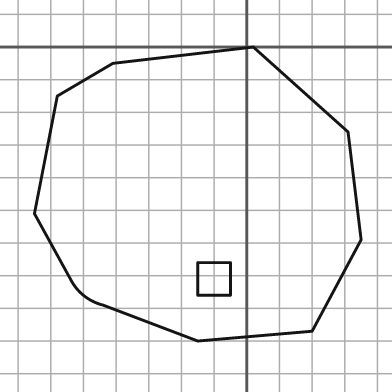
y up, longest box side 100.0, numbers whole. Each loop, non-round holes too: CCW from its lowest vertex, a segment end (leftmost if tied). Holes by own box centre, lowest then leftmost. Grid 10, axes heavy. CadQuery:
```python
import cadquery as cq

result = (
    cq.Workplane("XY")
    .moveTo(-15.0, -90.0)
    .lineTo(20.0, -87.0)
    .lineTo(35.0, -59.0)
    .lineTo(31.0, -26.0)
    .lineTo(2.0, 0.0)
    .lineTo(-41.0, -5.0)
    .lineTo(-58.0, -15.0)
    .lineTo(-65.0, -51.0)
    .lineTo(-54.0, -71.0)
    .threePointArc((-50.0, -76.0), (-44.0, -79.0))
    .close()
    .moveTo(-15.0, -76.0)
    .lineTo(-5.0, -76.0)
    .lineTo(-5.0, -66.0)
    .lineTo(-15.0, -66.0)
    .close()
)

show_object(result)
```